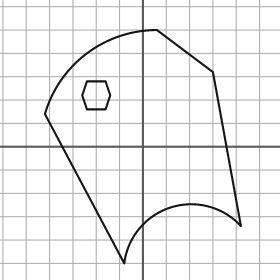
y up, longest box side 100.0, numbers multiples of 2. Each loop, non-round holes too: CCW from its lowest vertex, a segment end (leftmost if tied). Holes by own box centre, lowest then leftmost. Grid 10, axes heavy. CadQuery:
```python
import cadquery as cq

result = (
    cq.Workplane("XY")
    .moveTo(-8.0, -50.0)
    .threePointArc((12.0, -26.0), (42.0, -34.0))
    .lineTo(30.0, 32.0)
    .lineTo(6.0, 50.0)
    .threePointArc((-24.0, 40.0), (-42.0, 14.0))
    .close()
    .moveTo(-24.0, 16.0)
    .lineTo(-16.0, 16.0)
    .lineTo(-14.0, 22.0)
    .lineTo(-16.0, 28.0)
    .lineTo(-24.0, 28.0)
    .lineTo(-26.0, 22.0)
    .close()
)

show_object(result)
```